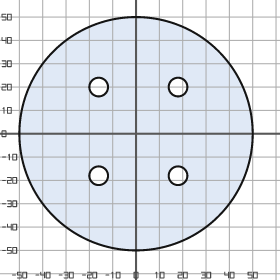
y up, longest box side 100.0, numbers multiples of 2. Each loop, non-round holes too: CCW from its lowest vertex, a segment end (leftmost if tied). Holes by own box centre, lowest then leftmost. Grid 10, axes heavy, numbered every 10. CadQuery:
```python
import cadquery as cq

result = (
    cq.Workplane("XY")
    .moveTo(0.0, 0.0)
    .circle(50.0)
    .moveTo(-16.0, -18.0)
    .circle(4.0)
    .moveTo(18.0, -18.0)
    .circle(4.0)
    .moveTo(-16.0, 20.0)
    .circle(4.0)
    .moveTo(18.0, 20.0)
    .circle(4.0)
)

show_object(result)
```